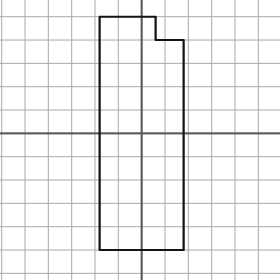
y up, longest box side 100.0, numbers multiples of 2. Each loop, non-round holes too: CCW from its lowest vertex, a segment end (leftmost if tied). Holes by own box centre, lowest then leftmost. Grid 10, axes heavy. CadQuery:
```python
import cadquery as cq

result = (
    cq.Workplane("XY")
    .moveTo(-18.0, -50.0)
    .lineTo(18.0, -50.0)
    .lineTo(18.0, 40.0)
    .lineTo(6.0, 40.0)
    .lineTo(6.0, 50.0)
    .lineTo(-18.0, 50.0)
    .close()
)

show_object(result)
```